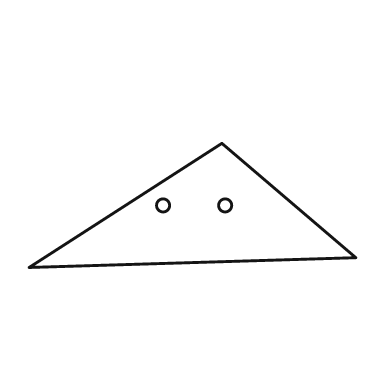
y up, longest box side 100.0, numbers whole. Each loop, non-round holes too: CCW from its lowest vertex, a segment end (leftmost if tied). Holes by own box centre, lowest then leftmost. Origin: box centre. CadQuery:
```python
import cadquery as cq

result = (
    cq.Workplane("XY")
    .moveTo(-50.0, -19.0)
    .lineTo(50.0, -16.0)
    .lineTo(9.0, 19.0)
    .close()
    .moveTo(-9.0, 0.0)
    .circle(2.0)
    .moveTo(10.0, 0.0)
    .circle(2.0)
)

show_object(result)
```